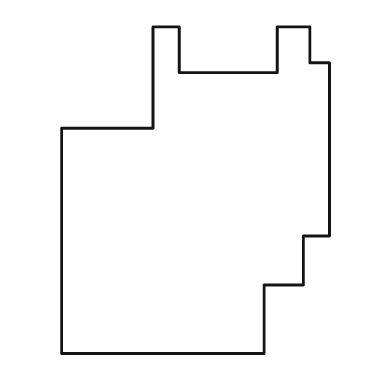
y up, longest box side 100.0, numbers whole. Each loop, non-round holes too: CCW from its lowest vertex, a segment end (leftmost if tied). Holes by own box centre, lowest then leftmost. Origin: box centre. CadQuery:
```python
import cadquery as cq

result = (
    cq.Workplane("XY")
    .moveTo(-41.0, -50.0)
    .lineTo(21.0, -50.0)
    .lineTo(21.0, -29.0)
    .lineTo(33.0, -29.0)
    .lineTo(33.0, -14.0)
    .lineTo(41.0, -14.0)
    .lineTo(41.0, 39.0)
    .lineTo(35.0, 39.0)
    .lineTo(35.0, 50.0)
    .lineTo(25.0, 50.0)
    .lineTo(25.0, 36.0)
    .lineTo(-5.0, 36.0)
    .lineTo(-5.0, 50.0)
    .lineTo(-13.0, 50.0)
    .lineTo(-13.0, 19.0)
    .lineTo(-41.0, 19.0)
    .close()
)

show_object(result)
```